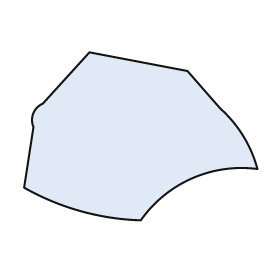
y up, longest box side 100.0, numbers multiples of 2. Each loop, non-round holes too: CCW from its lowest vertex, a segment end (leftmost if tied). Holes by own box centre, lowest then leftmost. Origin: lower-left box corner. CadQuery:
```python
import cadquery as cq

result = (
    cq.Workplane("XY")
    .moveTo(50.0, 0.0)
    .threePointArc((72.0, 18.0), (100.0, 22.0))
    .threePointArc((94.0, 36.0), (84.0, 48.0))
    .lineTo(70.0, 64.0)
    .lineTo(28.0, 72.0)
    .lineTo(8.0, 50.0)
    .threePointArc((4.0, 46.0), (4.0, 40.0))
    .lineTo(0.0, 14.0)
    .threePointArc((24.0, 4.0), (50.0, 0.0))
    .close()
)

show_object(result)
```